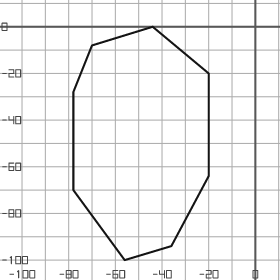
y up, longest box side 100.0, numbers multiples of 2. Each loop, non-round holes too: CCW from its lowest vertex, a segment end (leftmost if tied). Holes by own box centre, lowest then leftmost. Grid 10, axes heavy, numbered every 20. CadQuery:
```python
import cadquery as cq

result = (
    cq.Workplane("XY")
    .moveTo(-56.0, -100.0)
    .lineTo(-36.0, -94.0)
    .lineTo(-20.0, -64.0)
    .lineTo(-20.0, -20.0)
    .lineTo(-44.0, 0.0)
    .lineTo(-70.0, -8.0)
    .lineTo(-78.0, -28.0)
    .lineTo(-78.0, -70.0)
    .close()
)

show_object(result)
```